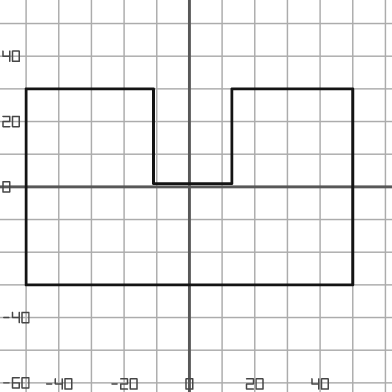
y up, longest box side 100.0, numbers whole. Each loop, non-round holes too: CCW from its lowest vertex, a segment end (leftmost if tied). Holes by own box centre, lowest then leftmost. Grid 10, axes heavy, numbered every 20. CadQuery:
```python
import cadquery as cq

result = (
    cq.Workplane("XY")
    .moveTo(-50.0, -30.0)
    .lineTo(50.0, -30.0)
    .lineTo(50.0, 30.0)
    .lineTo(13.0, 30.0)
    .lineTo(13.0, 1.0)
    .lineTo(-11.0, 1.0)
    .lineTo(-11.0, 30.0)
    .lineTo(-50.0, 30.0)
    .close()
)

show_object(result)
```